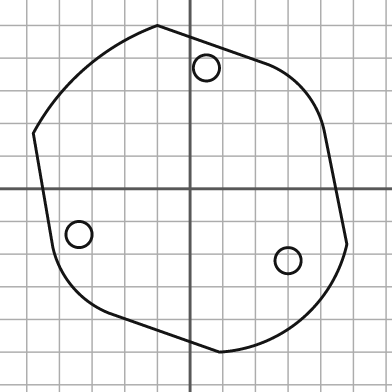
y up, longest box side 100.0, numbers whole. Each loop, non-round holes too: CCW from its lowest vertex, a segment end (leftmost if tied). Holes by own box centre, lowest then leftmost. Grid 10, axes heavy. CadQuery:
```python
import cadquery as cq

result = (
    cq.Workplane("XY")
    .moveTo(9.0, -50.0)
    .threePointArc((34.0, -40.0), (48.0, -17.0))
    .lineTo(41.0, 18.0)
    .threePointArc((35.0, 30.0), (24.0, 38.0))
    .lineTo(-10.0, 50.0)
    .threePointArc((-32.0, 37.0), (-48.0, 17.0))
    .lineTo(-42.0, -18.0)
    .threePointArc((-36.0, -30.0), (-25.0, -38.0))
    .close()
    .moveTo(30.0, -22.0)
    .circle(4.0)
    .moveTo(-34.0, -14.0)
    .circle(4.0)
    .moveTo(5.0, 37.0)
    .circle(4.0)
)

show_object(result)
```